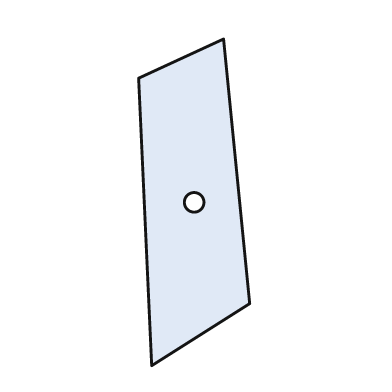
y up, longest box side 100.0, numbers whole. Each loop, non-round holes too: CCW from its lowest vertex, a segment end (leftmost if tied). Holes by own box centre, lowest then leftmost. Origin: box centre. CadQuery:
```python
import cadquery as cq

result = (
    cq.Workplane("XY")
    .moveTo(-13.0, -50.0)
    .lineTo(17.0, -31.0)
    .lineTo(9.0, 50.0)
    .lineTo(-17.0, 38.0)
    .close()
    .moveTo(0.0, 0.0)
    .circle(3.0)
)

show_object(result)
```